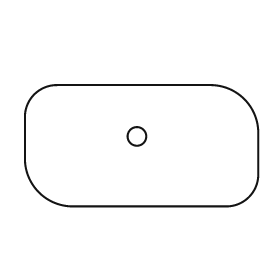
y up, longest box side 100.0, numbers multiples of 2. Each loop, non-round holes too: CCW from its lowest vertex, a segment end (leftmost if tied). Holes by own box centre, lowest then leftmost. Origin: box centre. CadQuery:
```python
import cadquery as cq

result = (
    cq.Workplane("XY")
    .moveTo(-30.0, -26.0)
    .lineTo(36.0, -26.0)
    .threePointArc((46.0, -22.0), (50.0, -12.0))
    .lineTo(50.0, 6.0)
    .threePointArc((44.0, 20.0), (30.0, 26.0))
    .lineTo(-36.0, 26.0)
    .threePointArc((-46.0, 22.0), (-50.0, 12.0))
    .lineTo(-50.0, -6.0)
    .threePointArc((-44.0, -20.0), (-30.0, -26.0))
    .close()
    .moveTo(-2.0, 4.0)
    .circle(4.0)
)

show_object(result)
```